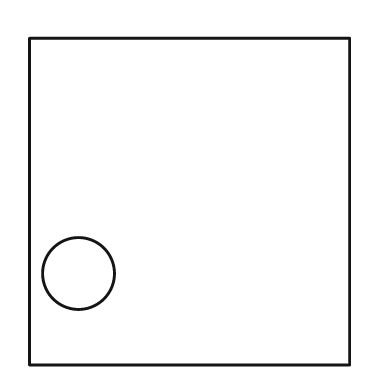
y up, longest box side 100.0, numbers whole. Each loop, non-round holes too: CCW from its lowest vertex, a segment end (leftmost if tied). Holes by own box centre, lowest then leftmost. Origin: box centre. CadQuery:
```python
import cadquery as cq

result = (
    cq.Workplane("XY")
    .moveTo(-49.0, -50.0)
    .lineTo(49.0, -50.0)
    .lineTo(49.0, 50.0)
    .lineTo(-49.0, 50.0)
    .close()
    .moveTo(-34.0, -22.0)
    .circle(11.0)
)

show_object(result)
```